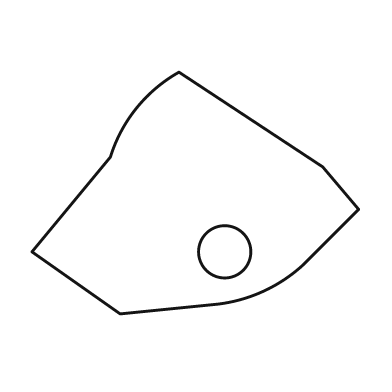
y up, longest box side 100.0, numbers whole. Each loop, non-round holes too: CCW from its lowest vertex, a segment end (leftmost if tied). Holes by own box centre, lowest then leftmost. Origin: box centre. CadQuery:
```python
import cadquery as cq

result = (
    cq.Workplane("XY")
    .moveTo(-23.0, -37.0)
    .lineTo(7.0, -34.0)
    .threePointArc((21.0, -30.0), (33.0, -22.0))
    .lineTo(50.0, -5.0)
    .lineTo(39.0, 8.0)
    .lineTo(-5.0, 37.0)
    .threePointArc((-18.0, 26.0), (-26.0, 11.0))
    .lineTo(-50.0, -18.0)
    .close()
    .moveTo(9.0, -18.0)
    .circle(8.0)
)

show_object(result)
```